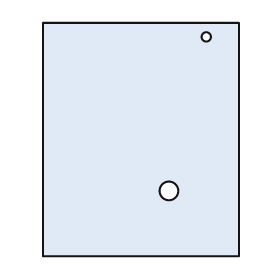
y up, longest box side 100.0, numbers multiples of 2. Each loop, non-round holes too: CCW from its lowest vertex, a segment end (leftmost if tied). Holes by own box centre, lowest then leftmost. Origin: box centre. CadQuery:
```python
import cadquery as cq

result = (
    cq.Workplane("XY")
    .moveTo(-42.0, -50.0)
    .lineTo(42.0, -50.0)
    .lineTo(42.0, 50.0)
    .lineTo(-42.0, 50.0)
    .close()
    .moveTo(12.0, -22.0)
    .circle(4.0)
    .moveTo(28.0, 44.0)
    .circle(2.0)
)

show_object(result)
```